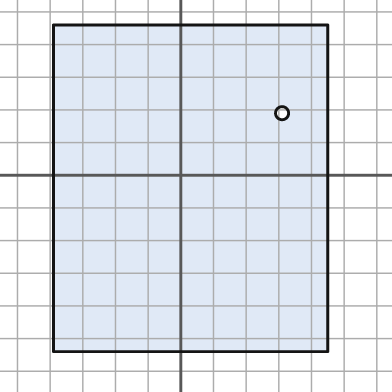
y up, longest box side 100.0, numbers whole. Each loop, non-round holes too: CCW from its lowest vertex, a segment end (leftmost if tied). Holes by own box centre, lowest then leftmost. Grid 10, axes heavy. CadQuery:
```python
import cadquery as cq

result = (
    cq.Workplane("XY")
    .moveTo(-39.0, -54.0)
    .lineTo(45.0, -54.0)
    .lineTo(45.0, 46.0)
    .lineTo(-39.0, 46.0)
    .close()
    .moveTo(31.0, 19.0)
    .circle(2.0)
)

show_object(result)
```